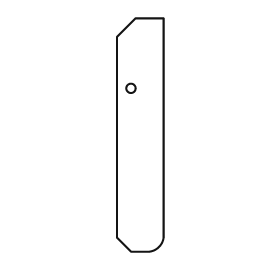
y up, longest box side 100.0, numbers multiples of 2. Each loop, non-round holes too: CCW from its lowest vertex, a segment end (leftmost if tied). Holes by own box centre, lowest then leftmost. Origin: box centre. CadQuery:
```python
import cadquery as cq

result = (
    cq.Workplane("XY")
    .moveTo(-4.0, -50.0)
    .lineTo(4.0, -50.0)
    .threePointArc((8.0, -48.0), (10.0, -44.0))
    .lineTo(10.0, 50.0)
    .lineTo(-2.0, 50.0)
    .lineTo(-10.0, 42.0)
    .lineTo(-10.0, -44.0)
    .close()
    .moveTo(-4.0, 20.0)
    .circle(2.0)
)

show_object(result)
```